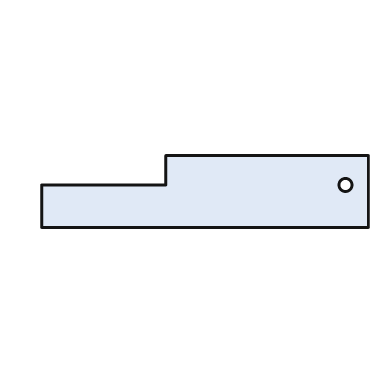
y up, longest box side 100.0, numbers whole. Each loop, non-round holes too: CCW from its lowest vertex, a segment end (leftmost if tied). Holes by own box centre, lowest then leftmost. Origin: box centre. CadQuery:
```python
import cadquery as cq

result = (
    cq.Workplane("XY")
    .moveTo(-50.0, -11.0)
    .lineTo(50.0, -11.0)
    .lineTo(50.0, 11.0)
    .lineTo(-12.0, 11.0)
    .lineTo(-12.0, 2.0)
    .lineTo(-50.0, 2.0)
    .close()
    .moveTo(43.0, 2.0)
    .circle(2.0)
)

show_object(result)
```